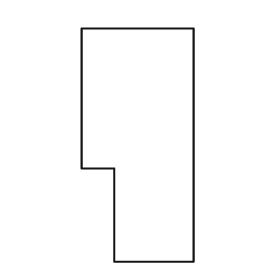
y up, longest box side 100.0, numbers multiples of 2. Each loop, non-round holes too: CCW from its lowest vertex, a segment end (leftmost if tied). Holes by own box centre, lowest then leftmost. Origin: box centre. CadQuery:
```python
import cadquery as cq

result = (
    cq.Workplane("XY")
    .moveTo(-10.0, -50.0)
    .lineTo(24.0, -50.0)
    .lineTo(24.0, 50.0)
    .lineTo(-24.0, 50.0)
    .lineTo(-24.0, -10.0)
    .lineTo(-10.0, -10.0)
    .close()
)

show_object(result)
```